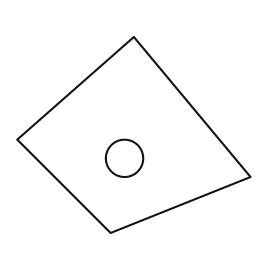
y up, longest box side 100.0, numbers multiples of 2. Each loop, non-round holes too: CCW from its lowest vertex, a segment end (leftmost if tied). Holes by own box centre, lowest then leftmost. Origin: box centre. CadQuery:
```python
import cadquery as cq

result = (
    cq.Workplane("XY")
    .moveTo(-10.0, -42.0)
    .lineTo(50.0, -18.0)
    .lineTo(0.0, 42.0)
    .lineTo(-50.0, -2.0)
    .close()
    .moveTo(-4.0, -10.0)
    .circle(8.0)
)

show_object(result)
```